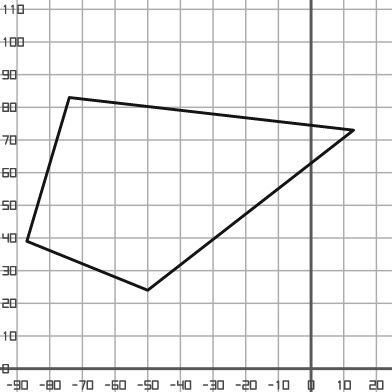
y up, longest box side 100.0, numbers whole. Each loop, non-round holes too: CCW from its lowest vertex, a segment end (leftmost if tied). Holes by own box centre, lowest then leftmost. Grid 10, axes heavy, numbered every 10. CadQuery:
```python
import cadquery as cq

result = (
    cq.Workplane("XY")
    .moveTo(-50.0, 24.0)
    .lineTo(13.0, 73.0)
    .lineTo(-74.0, 83.0)
    .lineTo(-87.0, 39.0)
    .close()
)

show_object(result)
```